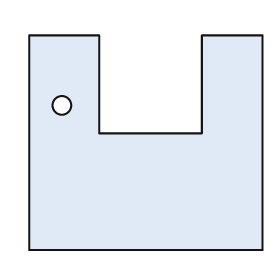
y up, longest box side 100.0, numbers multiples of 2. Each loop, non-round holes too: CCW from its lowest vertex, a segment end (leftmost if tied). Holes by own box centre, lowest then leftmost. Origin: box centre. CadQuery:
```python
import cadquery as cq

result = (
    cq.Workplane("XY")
    .moveTo(-50.0, -46.0)
    .lineTo(50.0, -46.0)
    .lineTo(50.0, 46.0)
    .lineTo(24.0, 46.0)
    .lineTo(24.0, 4.0)
    .lineTo(-20.0, 4.0)
    .lineTo(-20.0, 46.0)
    .lineTo(-50.0, 46.0)
    .close()
    .moveTo(-36.0, 16.0)
    .circle(4.0)
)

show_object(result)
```